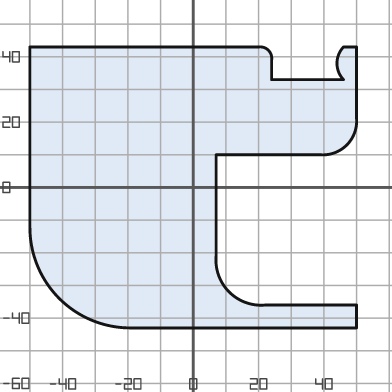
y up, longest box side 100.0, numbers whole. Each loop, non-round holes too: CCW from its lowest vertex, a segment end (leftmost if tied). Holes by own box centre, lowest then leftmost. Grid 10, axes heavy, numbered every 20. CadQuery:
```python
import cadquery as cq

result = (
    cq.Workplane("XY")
    .moveTo(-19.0, -43.0)
    .lineTo(50.0, -43.0)
    .lineTo(50.0, -36.0)
    .lineTo(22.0, -36.0)
    .threePointArc((11.0, -32.0), (7.0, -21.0))
    .lineTo(7.0, 10.0)
    .lineTo(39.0, 10.0)
    .threePointArc((47.0, 13.0), (50.0, 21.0))
    .lineTo(50.0, 43.0)
    .lineTo(46.0, 43.0)
    .threePointArc((44.0, 38.0), (46.0, 33.0))
    .lineTo(24.0, 33.0)
    .lineTo(24.0, 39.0)
    .threePointArc((23.0, 42.0), (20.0, 43.0))
    .lineTo(-50.0, 43.0)
    .lineTo(-50.0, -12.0)
    .threePointArc((-41.0, -34.0), (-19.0, -43.0))
    .close()
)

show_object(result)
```